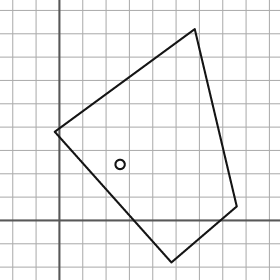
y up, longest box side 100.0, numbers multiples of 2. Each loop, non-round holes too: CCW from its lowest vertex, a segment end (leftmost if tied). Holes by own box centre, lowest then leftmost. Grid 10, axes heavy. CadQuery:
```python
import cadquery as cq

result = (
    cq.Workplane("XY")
    .moveTo(48.0, -18.0)
    .lineTo(76.0, 6.0)
    .lineTo(58.0, 82.0)
    .lineTo(-2.0, 38.0)
    .close()
    .moveTo(26.0, 24.0)
    .circle(2.0)
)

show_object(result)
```